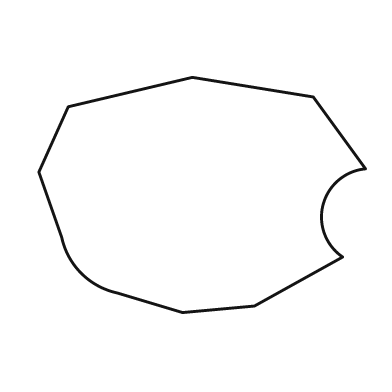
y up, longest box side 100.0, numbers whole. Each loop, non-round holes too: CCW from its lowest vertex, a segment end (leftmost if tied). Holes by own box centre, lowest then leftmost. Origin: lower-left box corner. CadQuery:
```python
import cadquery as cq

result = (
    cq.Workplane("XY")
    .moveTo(44.0, 0.0)
    .lineTo(66.0, 2.0)
    .lineTo(93.0, 17.0)
    .threePointArc((87.0, 33.0), (100.0, 44.0))
    .lineTo(84.0, 66.0)
    .lineTo(47.0, 72.0)
    .lineTo(9.0, 63.0)
    .lineTo(0.0, 43.0)
    .lineTo(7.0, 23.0)
    .threePointArc((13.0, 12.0), (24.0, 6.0))
    .close()
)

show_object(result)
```